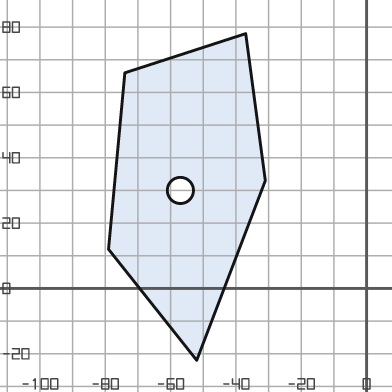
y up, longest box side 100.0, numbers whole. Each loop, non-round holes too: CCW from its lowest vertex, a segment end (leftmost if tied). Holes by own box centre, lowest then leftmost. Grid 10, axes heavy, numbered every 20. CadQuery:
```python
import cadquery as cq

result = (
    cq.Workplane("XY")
    .moveTo(-52.0, -22.0)
    .lineTo(-31.0, 33.0)
    .lineTo(-37.0, 78.0)
    .lineTo(-74.0, 66.0)
    .lineTo(-79.0, 12.0)
    .close()
    .moveTo(-57.0, 30.0)
    .circle(4.0)
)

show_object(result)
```